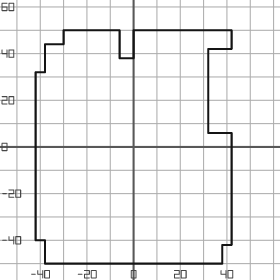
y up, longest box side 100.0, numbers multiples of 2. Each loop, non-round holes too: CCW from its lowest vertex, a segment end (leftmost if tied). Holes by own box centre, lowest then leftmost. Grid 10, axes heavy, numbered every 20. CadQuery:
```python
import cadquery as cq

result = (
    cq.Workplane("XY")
    .moveTo(-38.0, -50.0)
    .lineTo(38.0, -50.0)
    .lineTo(38.0, -42.0)
    .lineTo(42.0, -42.0)
    .lineTo(42.0, 6.0)
    .lineTo(32.0, 6.0)
    .lineTo(32.0, 42.0)
    .lineTo(42.0, 42.0)
    .lineTo(42.0, 50.0)
    .lineTo(0.0, 50.0)
    .lineTo(0.0, 38.0)
    .lineTo(-6.0, 38.0)
    .lineTo(-6.0, 50.0)
    .lineTo(-30.0, 50.0)
    .lineTo(-30.0, 44.0)
    .lineTo(-38.0, 44.0)
    .lineTo(-38.0, 32.0)
    .lineTo(-42.0, 32.0)
    .lineTo(-42.0, -40.0)
    .lineTo(-38.0, -40.0)
    .close()
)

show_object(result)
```